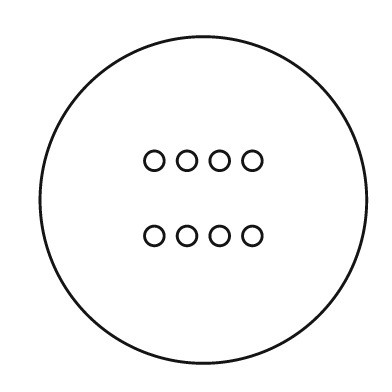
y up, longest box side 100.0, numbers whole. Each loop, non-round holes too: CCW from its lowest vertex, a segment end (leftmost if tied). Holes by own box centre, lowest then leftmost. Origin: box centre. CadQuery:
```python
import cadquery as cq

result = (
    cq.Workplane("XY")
    .moveTo(0.0, 0.0)
    .circle(50.0)
    .moveTo(-15.0, -11.0)
    .circle(3.0)
    .moveTo(-5.0, -11.0)
    .circle(3.0)
    .moveTo(5.0, -11.0)
    .circle(3.0)
    .moveTo(15.0, -11.0)
    .circle(3.0)
    .moveTo(-15.0, 12.0)
    .circle(3.0)
    .moveTo(-5.0, 12.0)
    .circle(3.0)
    .moveTo(5.0, 12.0)
    .circle(3.0)
    .moveTo(15.0, 12.0)
    .circle(3.0)
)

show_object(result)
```